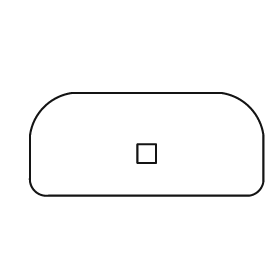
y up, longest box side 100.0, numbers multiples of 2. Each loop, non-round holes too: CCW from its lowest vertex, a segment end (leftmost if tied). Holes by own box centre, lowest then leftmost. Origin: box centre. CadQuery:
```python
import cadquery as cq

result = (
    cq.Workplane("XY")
    .moveTo(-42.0, -22.0)
    .lineTo(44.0, -22.0)
    .threePointArc((48.0, -20.0), (50.0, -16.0))
    .lineTo(50.0, 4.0)
    .threePointArc((44.0, 16.0), (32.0, 22.0))
    .lineTo(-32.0, 22.0)
    .threePointArc((-44.0, 16.0), (-50.0, 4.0))
    .lineTo(-50.0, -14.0)
    .threePointArc((-48.0, -20.0), (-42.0, -22.0))
    .close()
    .moveTo(-4.0, -8.0)
    .lineTo(4.0, -8.0)
    .lineTo(4.0, 0.0)
    .lineTo(-4.0, 0.0)
    .close()
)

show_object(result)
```